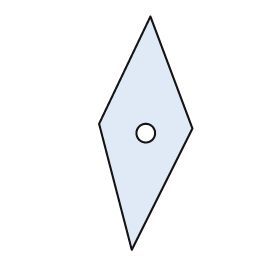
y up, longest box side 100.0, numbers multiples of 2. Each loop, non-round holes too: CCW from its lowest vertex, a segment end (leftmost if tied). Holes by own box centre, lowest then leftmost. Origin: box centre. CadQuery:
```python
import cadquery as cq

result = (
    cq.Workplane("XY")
    .moveTo(-6.0, -50.0)
    .lineTo(20.0, 2.0)
    .lineTo(2.0, 50.0)
    .lineTo(-20.0, 4.0)
    .close()
    .moveTo(0.0, 0.0)
    .circle(4.0)
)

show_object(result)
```